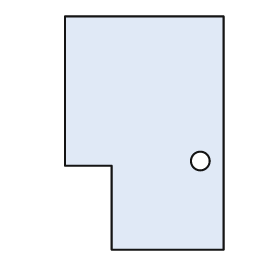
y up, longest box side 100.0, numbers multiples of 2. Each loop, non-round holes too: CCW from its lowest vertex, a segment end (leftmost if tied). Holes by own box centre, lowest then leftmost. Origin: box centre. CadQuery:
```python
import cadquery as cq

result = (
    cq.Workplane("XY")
    .moveTo(-14.0, -50.0)
    .lineTo(34.0, -50.0)
    .lineTo(34.0, 50.0)
    .lineTo(-34.0, 50.0)
    .lineTo(-34.0, -14.0)
    .lineTo(-14.0, -14.0)
    .close()
    .moveTo(24.0, -12.0)
    .circle(4.0)
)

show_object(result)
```